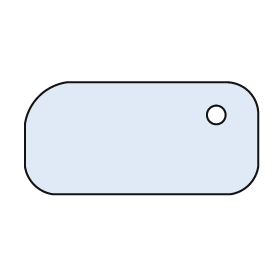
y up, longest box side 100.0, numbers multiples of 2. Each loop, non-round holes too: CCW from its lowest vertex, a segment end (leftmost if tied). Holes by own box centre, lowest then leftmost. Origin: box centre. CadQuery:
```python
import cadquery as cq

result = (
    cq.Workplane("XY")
    .moveTo(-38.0, -24.0)
    .lineTo(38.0, -24.0)
    .threePointArc((46.0, -20.0), (50.0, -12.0))
    .lineTo(50.0, 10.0)
    .threePointArc((46.0, 20.0), (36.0, 24.0))
    .lineTo(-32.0, 24.0)
    .threePointArc((-44.0, 18.0), (-50.0, 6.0))
    .lineTo(-50.0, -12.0)
    .threePointArc((-46.0, -20.0), (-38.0, -24.0))
    .close()
    .moveTo(32.0, 10.0)
    .circle(4.0)
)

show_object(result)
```